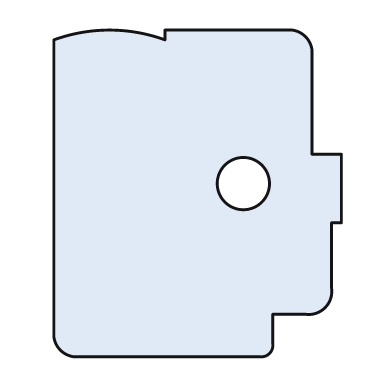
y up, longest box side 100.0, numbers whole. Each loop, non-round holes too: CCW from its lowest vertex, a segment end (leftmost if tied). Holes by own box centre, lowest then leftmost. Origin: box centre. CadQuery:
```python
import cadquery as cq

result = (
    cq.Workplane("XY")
    .moveTo(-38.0, -50.0)
    .lineTo(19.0, -50.0)
    .threePointArc((22.0, -49.0), (23.0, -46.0))
    .lineTo(23.0, -37.0)
    .lineTo(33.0, -37.0)
    .threePointArc((39.0, -35.0), (41.0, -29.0))
    .lineTo(41.0, -9.0)
    .lineTo(44.0, -9.0)
    .lineTo(44.0, 12.0)
    .lineTo(35.0, 12.0)
    .lineTo(35.0, 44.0)
    .threePointArc((33.0, 48.0), (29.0, 50.0))
    .lineTo(-10.0, 50.0)
    .lineTo(-10.0, 47.0)
    .threePointArc((-27.0, 50.0), (-44.0, 47.0))
    .lineTo(-44.0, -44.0)
    .threePointArc((-42.0, -48.0), (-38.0, -50.0))
    .close()
    .moveTo(14.0, 3.0)
    .circle(8.0)
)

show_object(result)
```